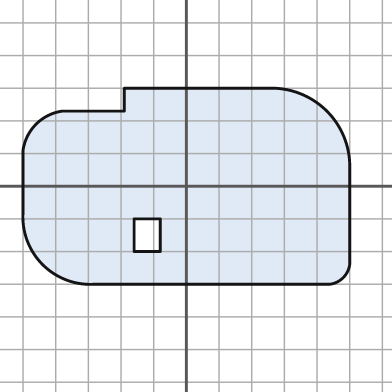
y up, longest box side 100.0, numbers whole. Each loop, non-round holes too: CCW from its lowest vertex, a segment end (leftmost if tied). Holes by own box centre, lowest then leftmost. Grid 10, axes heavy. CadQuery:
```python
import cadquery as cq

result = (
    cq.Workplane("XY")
    .moveTo(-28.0, -30.0)
    .lineTo(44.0, -30.0)
    .threePointArc((48.0, -28.0), (50.0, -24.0))
    .lineTo(50.0, 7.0)
    .threePointArc((43.0, 23.0), (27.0, 30.0))
    .lineTo(-19.0, 30.0)
    .lineTo(-19.0, 23.0)
    .lineTo(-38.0, 23.0)
    .threePointArc((-46.0, 19.0), (-50.0, 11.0))
    .lineTo(-50.0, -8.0)
    .threePointArc((-44.0, -24.0), (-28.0, -30.0))
    .close()
    .moveTo(-16.0, -20.0)
    .lineTo(-8.0, -20.0)
    .lineTo(-8.0, -10.0)
    .lineTo(-16.0, -10.0)
    .close()
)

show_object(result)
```